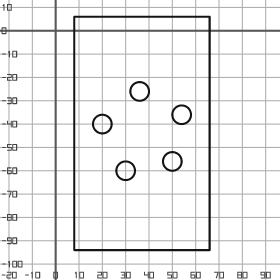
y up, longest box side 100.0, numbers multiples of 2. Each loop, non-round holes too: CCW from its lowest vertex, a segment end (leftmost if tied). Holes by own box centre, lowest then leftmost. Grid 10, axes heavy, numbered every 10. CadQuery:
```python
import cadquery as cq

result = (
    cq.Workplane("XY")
    .moveTo(8.0, -94.0)
    .lineTo(66.0, -94.0)
    .lineTo(66.0, 6.0)
    .lineTo(8.0, 6.0)
    .close()
    .moveTo(30.0, -60.0)
    .circle(4.0)
    .moveTo(50.0, -56.0)
    .circle(4.0)
    .moveTo(20.0, -40.0)
    .circle(4.0)
    .moveTo(54.0, -36.0)
    .circle(4.0)
    .moveTo(36.0, -26.0)
    .circle(4.0)
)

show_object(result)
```